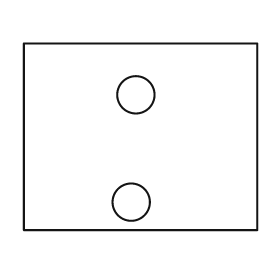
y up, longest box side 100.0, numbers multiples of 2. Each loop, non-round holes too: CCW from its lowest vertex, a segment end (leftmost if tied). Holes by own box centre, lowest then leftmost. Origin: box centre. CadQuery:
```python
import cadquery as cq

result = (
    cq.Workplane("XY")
    .moveTo(-50.0, -40.0)
    .lineTo(50.0, -40.0)
    .lineTo(50.0, 40.0)
    .lineTo(-50.0, 40.0)
    .close()
    .moveTo(-4.0, -28.0)
    .circle(8.0)
    .moveTo(-2.0, 18.0)
    .circle(8.0)
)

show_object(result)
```